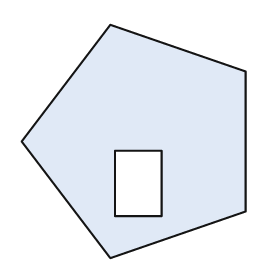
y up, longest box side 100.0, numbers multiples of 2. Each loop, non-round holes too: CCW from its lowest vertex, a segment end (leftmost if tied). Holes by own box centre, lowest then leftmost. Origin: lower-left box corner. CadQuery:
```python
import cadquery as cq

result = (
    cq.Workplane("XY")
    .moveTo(38.0, 0.0)
    .lineTo(96.0, 20.0)
    .lineTo(96.0, 80.0)
    .lineTo(38.0, 100.0)
    .lineTo(0.0, 50.0)
    .close()
    .moveTo(40.0, 18.0)
    .lineTo(60.0, 18.0)
    .lineTo(60.0, 46.0)
    .lineTo(40.0, 46.0)
    .close()
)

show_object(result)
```